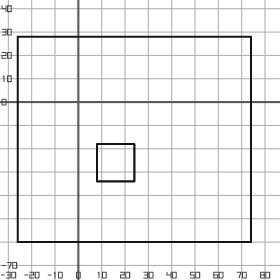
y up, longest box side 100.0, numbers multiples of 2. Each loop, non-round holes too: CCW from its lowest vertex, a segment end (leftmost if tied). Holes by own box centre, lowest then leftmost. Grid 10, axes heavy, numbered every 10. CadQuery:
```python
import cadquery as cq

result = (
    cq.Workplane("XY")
    .moveTo(-26.0, -60.0)
    .lineTo(74.0, -60.0)
    .lineTo(74.0, 28.0)
    .lineTo(-26.0, 28.0)
    .close()
    .moveTo(8.0, -34.0)
    .lineTo(24.0, -34.0)
    .lineTo(24.0, -18.0)
    .lineTo(8.0, -18.0)
    .close()
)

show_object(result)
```